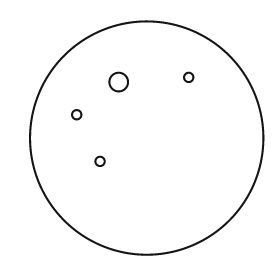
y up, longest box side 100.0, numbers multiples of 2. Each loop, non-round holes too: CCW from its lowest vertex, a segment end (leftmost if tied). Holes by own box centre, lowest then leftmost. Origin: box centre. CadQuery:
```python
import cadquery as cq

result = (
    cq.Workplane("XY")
    .moveTo(0.0, 0.0)
    .circle(50.0)
    .moveTo(-20.0, -10.0)
    .circle(2.0)
    .moveTo(-30.0, 10.0)
    .circle(2.0)
    .moveTo(-12.0, 24.0)
    .circle(4.0)
    .moveTo(18.0, 26.0)
    .circle(2.0)
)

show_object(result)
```